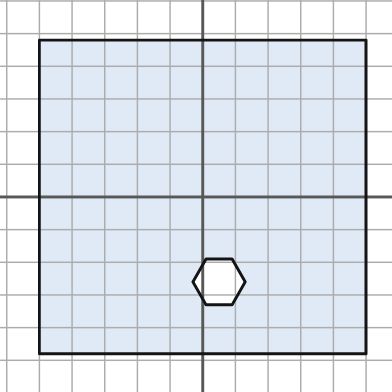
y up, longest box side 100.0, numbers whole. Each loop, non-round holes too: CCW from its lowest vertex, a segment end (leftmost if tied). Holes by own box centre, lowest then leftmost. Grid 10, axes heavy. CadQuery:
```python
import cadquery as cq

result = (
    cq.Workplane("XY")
    .moveTo(-50.0, -48.0)
    .lineTo(50.0, -48.0)
    .lineTo(50.0, 48.0)
    .lineTo(-50.0, 48.0)
    .close()
    .moveTo(1.0, -33.0)
    .lineTo(9.0, -33.0)
    .lineTo(13.0, -26.0)
    .lineTo(9.0, -19.0)
    .lineTo(1.0, -19.0)
    .lineTo(-3.0, -26.0)
    .close()
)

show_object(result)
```